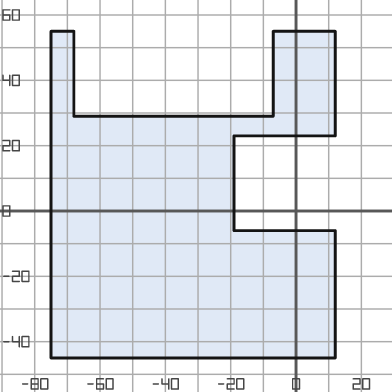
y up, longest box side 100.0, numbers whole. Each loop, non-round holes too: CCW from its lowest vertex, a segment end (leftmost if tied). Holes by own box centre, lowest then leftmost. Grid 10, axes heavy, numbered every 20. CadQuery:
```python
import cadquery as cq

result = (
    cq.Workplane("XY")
    .moveTo(-75.0, -45.0)
    .lineTo(12.0, -45.0)
    .lineTo(12.0, -6.0)
    .lineTo(-19.0, -6.0)
    .lineTo(-19.0, 23.0)
    .lineTo(12.0, 23.0)
    .lineTo(12.0, 55.0)
    .lineTo(-7.0, 55.0)
    .lineTo(-7.0, 29.0)
    .lineTo(-68.0, 29.0)
    .lineTo(-68.0, 55.0)
    .lineTo(-75.0, 55.0)
    .close()
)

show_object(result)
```